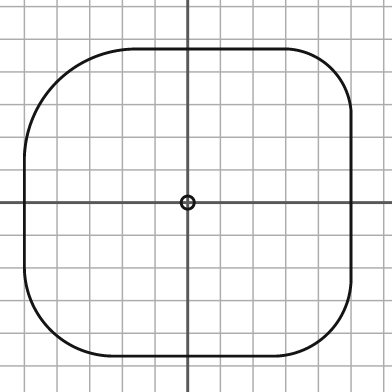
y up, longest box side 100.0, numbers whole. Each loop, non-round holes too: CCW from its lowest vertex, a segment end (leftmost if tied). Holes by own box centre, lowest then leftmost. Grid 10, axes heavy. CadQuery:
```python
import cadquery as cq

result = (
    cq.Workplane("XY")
    .moveTo(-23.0, -47.0)
    .lineTo(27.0, -47.0)
    .threePointArc((43.0, -40.0), (50.0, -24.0))
    .lineTo(50.0, 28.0)
    .threePointArc((44.0, 41.0), (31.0, 47.0))
    .lineTo(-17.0, 47.0)
    .threePointArc((-40.0, 37.0), (-50.0, 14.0))
    .lineTo(-50.0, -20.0)
    .threePointArc((-42.0, -39.0), (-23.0, -47.0))
    .close()
    .moveTo(0.0, 0.0)
    .circle(2.0)
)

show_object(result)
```